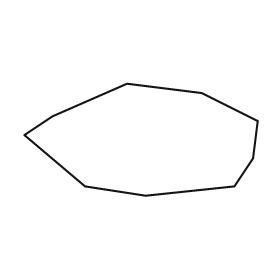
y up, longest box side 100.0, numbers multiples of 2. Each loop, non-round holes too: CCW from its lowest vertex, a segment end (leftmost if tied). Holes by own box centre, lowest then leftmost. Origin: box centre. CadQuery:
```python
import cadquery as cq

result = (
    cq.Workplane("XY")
    .moveTo(2.0, -24.0)
    .lineTo(40.0, -20.0)
    .lineTo(48.0, -8.0)
    .lineTo(50.0, 8.0)
    .lineTo(26.0, 20.0)
    .lineTo(-6.0, 24.0)
    .lineTo(-38.0, 10.0)
    .lineTo(-50.0, 2.0)
    .lineTo(-24.0, -20.0)
    .close()
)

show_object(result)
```